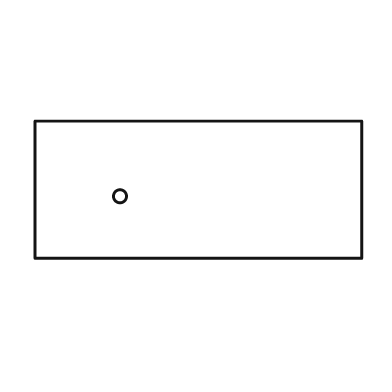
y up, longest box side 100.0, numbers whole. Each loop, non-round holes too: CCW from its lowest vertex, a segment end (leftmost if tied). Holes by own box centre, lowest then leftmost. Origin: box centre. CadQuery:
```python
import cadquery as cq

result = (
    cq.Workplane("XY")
    .moveTo(-50.0, -21.0)
    .lineTo(50.0, -21.0)
    .lineTo(50.0, 21.0)
    .lineTo(-50.0, 21.0)
    .close()
    .moveTo(-24.0, -2.0)
    .circle(2.0)
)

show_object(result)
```